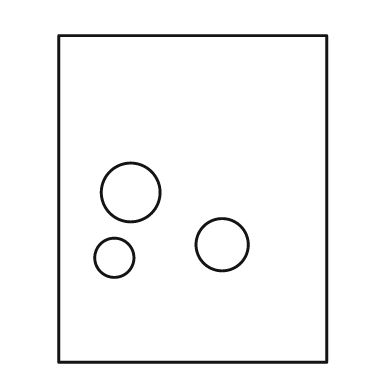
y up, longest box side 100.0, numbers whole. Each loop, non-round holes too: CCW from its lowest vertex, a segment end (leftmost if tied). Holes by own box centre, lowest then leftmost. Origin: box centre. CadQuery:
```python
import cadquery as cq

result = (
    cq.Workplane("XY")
    .moveTo(-41.0, -50.0)
    .lineTo(41.0, -50.0)
    .lineTo(41.0, 50.0)
    .lineTo(-41.0, 50.0)
    .close()
    .moveTo(-24.0, -18.0)
    .circle(6.0)
    .moveTo(9.0, -14.0)
    .circle(8.0)
    .moveTo(-19.0, 2.0)
    .circle(9.0)
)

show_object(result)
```